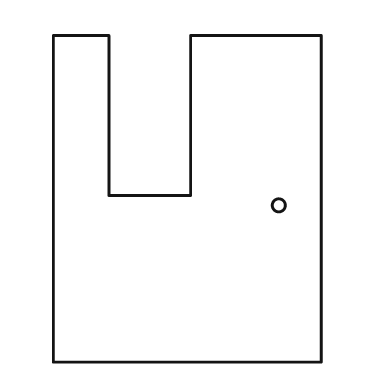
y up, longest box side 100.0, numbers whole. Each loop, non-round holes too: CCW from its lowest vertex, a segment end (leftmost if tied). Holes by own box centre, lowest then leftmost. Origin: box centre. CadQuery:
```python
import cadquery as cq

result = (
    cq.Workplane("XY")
    .moveTo(-41.0, -50.0)
    .lineTo(41.0, -50.0)
    .lineTo(41.0, 50.0)
    .lineTo(1.0, 50.0)
    .lineTo(1.0, 1.0)
    .lineTo(-24.0, 1.0)
    .lineTo(-24.0, 50.0)
    .lineTo(-41.0, 50.0)
    .close()
    .moveTo(28.0, -2.0)
    .circle(2.0)
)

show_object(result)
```